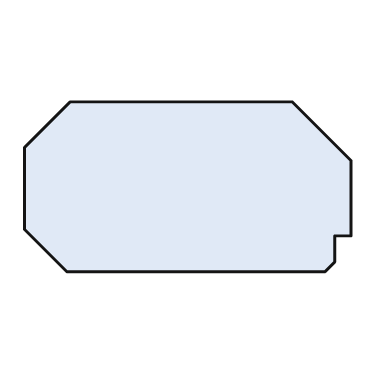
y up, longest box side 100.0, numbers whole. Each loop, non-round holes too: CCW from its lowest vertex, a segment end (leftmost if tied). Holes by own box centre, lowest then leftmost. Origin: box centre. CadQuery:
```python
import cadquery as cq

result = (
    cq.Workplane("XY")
    .moveTo(-37.0, -26.0)
    .lineTo(42.0, -26.0)
    .lineTo(45.0, -23.0)
    .lineTo(45.0, -15.0)
    .lineTo(50.0, -15.0)
    .lineTo(50.0, 8.0)
    .lineTo(32.0, 26.0)
    .lineTo(-36.0, 26.0)
    .lineTo(-50.0, 12.0)
    .lineTo(-50.0, -13.0)
    .close()
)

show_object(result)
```